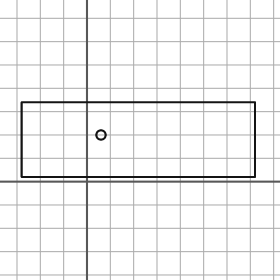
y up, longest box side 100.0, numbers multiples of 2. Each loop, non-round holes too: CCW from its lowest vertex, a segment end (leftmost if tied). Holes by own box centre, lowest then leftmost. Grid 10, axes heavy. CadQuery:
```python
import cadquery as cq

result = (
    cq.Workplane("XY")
    .moveTo(-28.0, 2.0)
    .lineTo(72.0, 2.0)
    .lineTo(72.0, 34.0)
    .lineTo(-28.0, 34.0)
    .close()
    .moveTo(6.0, 20.0)
    .circle(2.0)
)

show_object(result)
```